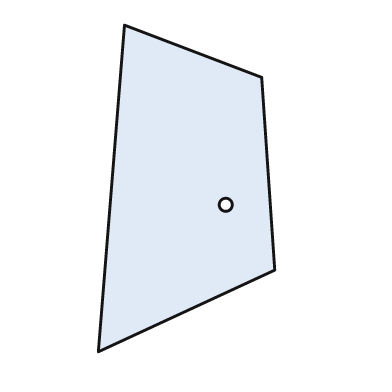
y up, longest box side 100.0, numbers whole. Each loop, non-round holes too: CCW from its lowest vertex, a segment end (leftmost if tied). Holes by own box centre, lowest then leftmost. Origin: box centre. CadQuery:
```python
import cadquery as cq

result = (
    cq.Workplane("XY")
    .moveTo(-27.0, -50.0)
    .lineTo(27.0, -25.0)
    .lineTo(23.0, 34.0)
    .lineTo(-19.0, 50.0)
    .close()
    .moveTo(12.0, -5.0)
    .circle(2.0)
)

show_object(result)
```